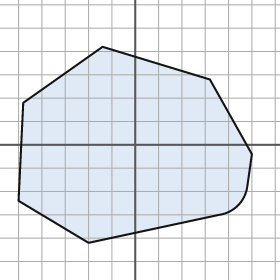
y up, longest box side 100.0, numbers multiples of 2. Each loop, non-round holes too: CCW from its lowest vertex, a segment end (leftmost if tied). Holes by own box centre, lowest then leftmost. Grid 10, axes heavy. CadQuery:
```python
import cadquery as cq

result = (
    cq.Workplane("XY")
    .moveTo(-20.0, -42.0)
    .lineTo(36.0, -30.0)
    .threePointArc((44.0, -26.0), (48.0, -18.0))
    .lineTo(50.0, -4.0)
    .lineTo(32.0, 28.0)
    .lineTo(-14.0, 42.0)
    .lineTo(-48.0, 18.0)
    .lineTo(-50.0, -24.0)
    .close()
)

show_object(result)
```